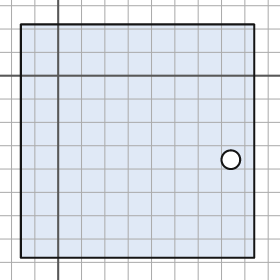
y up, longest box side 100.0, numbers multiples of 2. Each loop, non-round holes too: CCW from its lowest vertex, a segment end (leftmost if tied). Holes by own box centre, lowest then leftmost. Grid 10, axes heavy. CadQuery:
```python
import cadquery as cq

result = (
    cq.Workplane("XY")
    .moveTo(-16.0, -78.0)
    .lineTo(84.0, -78.0)
    .lineTo(84.0, 22.0)
    .lineTo(-16.0, 22.0)
    .close()
    .moveTo(74.0, -36.0)
    .circle(4.0)
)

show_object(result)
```